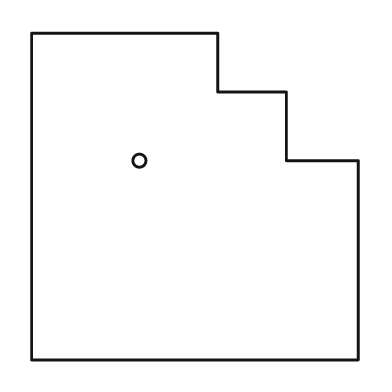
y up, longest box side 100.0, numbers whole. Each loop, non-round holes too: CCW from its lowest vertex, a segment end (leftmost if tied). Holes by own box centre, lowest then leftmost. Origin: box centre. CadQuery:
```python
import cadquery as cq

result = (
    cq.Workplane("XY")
    .moveTo(-50.0, -50.0)
    .lineTo(50.0, -50.0)
    .lineTo(50.0, 11.0)
    .lineTo(28.0, 11.0)
    .lineTo(28.0, 32.0)
    .lineTo(7.0, 32.0)
    .lineTo(7.0, 50.0)
    .lineTo(-50.0, 50.0)
    .close()
    .moveTo(-17.0, 11.0)
    .circle(2.0)
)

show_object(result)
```